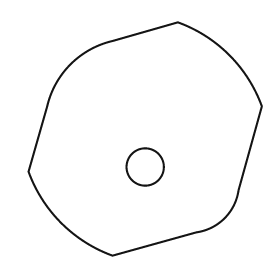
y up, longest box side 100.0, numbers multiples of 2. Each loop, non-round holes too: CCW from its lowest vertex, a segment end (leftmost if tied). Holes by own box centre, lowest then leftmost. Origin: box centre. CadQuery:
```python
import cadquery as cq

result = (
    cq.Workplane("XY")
    .moveTo(-14.0, -50.0)
    .lineTo(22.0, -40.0)
    .threePointArc((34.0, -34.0), (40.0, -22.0))
    .lineTo(50.0, 14.0)
    .threePointArc((36.0, 36.0), (14.0, 50.0))
    .lineTo(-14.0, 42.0)
    .threePointArc((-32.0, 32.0), (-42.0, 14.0))
    .lineTo(-50.0, -14.0)
    .threePointArc((-36.0, -36.0), (-14.0, -50.0))
    .close()
    .moveTo(0.0, -12.0)
    .circle(8.0)
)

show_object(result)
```